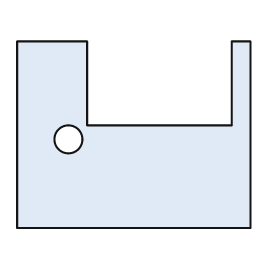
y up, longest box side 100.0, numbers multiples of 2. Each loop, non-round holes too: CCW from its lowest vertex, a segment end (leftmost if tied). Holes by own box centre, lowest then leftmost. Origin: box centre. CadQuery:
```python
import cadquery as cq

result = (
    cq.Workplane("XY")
    .moveTo(-50.0, -40.0)
    .lineTo(50.0, -40.0)
    .lineTo(50.0, 40.0)
    .lineTo(42.0, 40.0)
    .lineTo(42.0, 4.0)
    .lineTo(-20.0, 4.0)
    .lineTo(-20.0, 40.0)
    .lineTo(-50.0, 40.0)
    .close()
    .moveTo(-28.0, -2.0)
    .circle(6.0)
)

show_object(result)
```